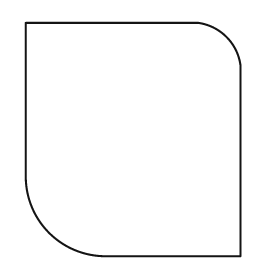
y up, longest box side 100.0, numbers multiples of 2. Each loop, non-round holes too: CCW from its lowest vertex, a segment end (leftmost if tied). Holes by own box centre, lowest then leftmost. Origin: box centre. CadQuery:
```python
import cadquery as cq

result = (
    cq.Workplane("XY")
    .moveTo(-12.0, -50.0)
    .lineTo(46.0, -50.0)
    .lineTo(46.0, 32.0)
    .threePointArc((40.0, 44.0), (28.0, 50.0))
    .lineTo(-46.0, 50.0)
    .lineTo(-46.0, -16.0)
    .threePointArc((-36.0, -40.0), (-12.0, -50.0))
    .close()
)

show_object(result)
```